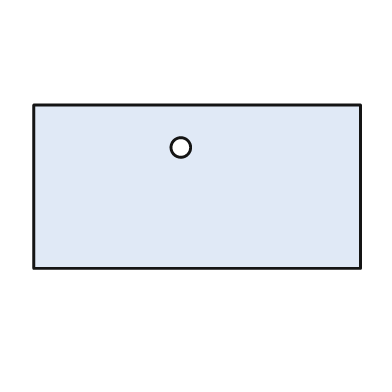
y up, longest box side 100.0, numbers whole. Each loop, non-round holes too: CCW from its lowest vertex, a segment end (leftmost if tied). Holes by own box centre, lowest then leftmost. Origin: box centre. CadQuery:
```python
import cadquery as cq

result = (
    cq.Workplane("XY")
    .moveTo(-50.0, -25.0)
    .lineTo(50.0, -25.0)
    .lineTo(50.0, 25.0)
    .lineTo(-50.0, 25.0)
    .close()
    .moveTo(-5.0, 12.0)
    .circle(3.0)
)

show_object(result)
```